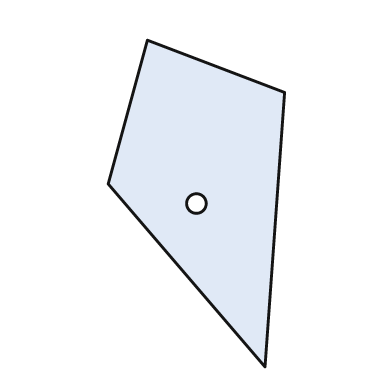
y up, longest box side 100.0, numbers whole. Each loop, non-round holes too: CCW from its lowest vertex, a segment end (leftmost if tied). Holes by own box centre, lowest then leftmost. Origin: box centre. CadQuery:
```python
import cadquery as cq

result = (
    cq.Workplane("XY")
    .moveTo(21.0, -50.0)
    .lineTo(27.0, 34.0)
    .lineTo(-15.0, 50.0)
    .lineTo(-27.0, 6.0)
    .close()
    .moveTo(0.0, 0.0)
    .circle(3.0)
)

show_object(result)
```